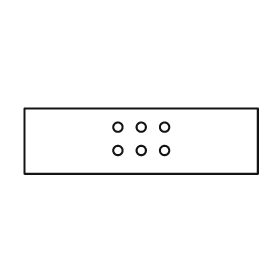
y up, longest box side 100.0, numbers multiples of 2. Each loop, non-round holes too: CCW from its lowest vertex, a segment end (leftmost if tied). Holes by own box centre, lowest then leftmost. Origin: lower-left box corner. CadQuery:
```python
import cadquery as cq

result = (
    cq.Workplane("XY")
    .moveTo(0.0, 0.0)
    .lineTo(100.0, 0.0)
    .lineTo(100.0, 28.0)
    .lineTo(0.0, 28.0)
    .close()
    .moveTo(40.0, 10.0)
    .circle(2.0)
    .moveTo(50.0, 10.0)
    .circle(2.0)
    .moveTo(60.0, 10.0)
    .circle(2.0)
    .moveTo(40.0, 20.0)
    .circle(2.0)
    .moveTo(50.0, 20.0)
    .circle(2.0)
    .moveTo(60.0, 20.0)
    .circle(2.0)
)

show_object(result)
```